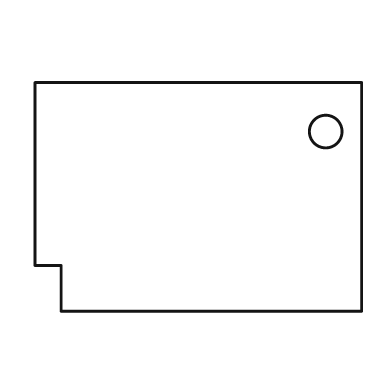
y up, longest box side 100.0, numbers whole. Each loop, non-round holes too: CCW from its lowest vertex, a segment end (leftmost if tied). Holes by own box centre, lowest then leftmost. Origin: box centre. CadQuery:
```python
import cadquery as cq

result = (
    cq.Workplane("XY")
    .moveTo(-42.0, -35.0)
    .lineTo(50.0, -35.0)
    .lineTo(50.0, 35.0)
    .lineTo(-50.0, 35.0)
    .lineTo(-50.0, -21.0)
    .lineTo(-42.0, -21.0)
    .close()
    .moveTo(39.0, 20.0)
    .circle(5.0)
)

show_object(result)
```